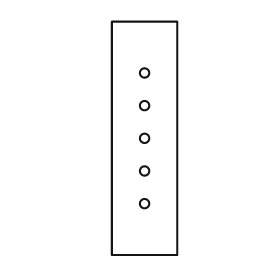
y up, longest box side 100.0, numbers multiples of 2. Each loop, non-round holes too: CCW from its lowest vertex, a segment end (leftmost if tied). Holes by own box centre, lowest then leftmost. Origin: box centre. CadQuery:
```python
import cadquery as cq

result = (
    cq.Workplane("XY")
    .moveTo(-14.0, -50.0)
    .lineTo(14.0, -50.0)
    .lineTo(14.0, 50.0)
    .lineTo(-14.0, 50.0)
    .close()
    .moveTo(0.0, -28.0)
    .circle(2.0)
    .moveTo(0.0, -14.0)
    .circle(2.0)
    .moveTo(0.0, 0.0)
    .circle(2.0)
    .moveTo(0.0, 14.0)
    .circle(2.0)
    .moveTo(0.0, 28.0)
    .circle(2.0)
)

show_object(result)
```